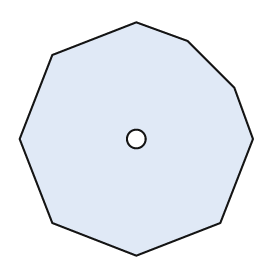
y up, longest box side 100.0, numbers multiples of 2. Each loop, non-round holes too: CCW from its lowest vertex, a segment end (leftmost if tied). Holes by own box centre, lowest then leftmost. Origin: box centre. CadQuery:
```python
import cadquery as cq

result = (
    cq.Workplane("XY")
    .moveTo(0.0, -50.0)
    .lineTo(36.0, -36.0)
    .lineTo(50.0, 0.0)
    .lineTo(42.0, 22.0)
    .lineTo(22.0, 42.0)
    .lineTo(0.0, 50.0)
    .lineTo(-36.0, 36.0)
    .lineTo(-50.0, 0.0)
    .lineTo(-36.0, -36.0)
    .close()
    .moveTo(0.0, 0.0)
    .circle(4.0)
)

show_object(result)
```